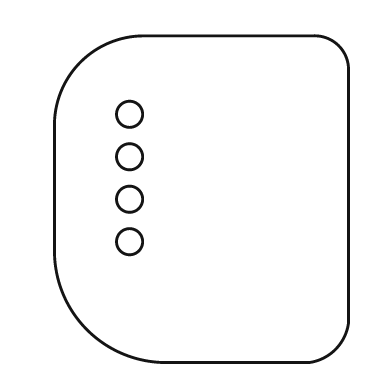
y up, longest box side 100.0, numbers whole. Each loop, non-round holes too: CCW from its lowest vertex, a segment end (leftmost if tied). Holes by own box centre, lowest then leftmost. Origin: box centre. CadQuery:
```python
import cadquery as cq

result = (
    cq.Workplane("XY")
    .moveTo(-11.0, -50.0)
    .lineTo(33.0, -50.0)
    .threePointArc((41.0, -46.0), (45.0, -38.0))
    .lineTo(45.0, 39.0)
    .threePointArc((42.0, 47.0), (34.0, 50.0))
    .lineTo(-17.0, 50.0)
    .threePointArc((-37.0, 42.0), (-45.0, 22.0))
    .lineTo(-45.0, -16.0)
    .threePointArc((-35.0, -40.0), (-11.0, -50.0))
    .close()
    .moveTo(-22.0, -13.0)
    .circle(4.0)
    .moveTo(-22.0, 0.0)
    .circle(4.0)
    .moveTo(-22.0, 13.0)
    .circle(4.0)
    .moveTo(-22.0, 26.0)
    .circle(4.0)
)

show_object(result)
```